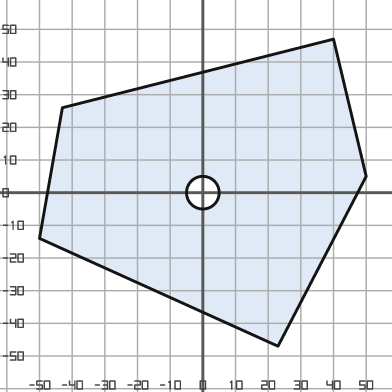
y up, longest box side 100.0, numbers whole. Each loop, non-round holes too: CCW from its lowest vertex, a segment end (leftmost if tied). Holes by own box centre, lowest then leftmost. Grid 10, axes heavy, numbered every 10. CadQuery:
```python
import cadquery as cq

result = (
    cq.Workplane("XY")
    .moveTo(23.0, -47.0)
    .lineTo(50.0, 5.0)
    .lineTo(40.0, 47.0)
    .lineTo(-43.0, 26.0)
    .lineTo(-50.0, -14.0)
    .close()
    .moveTo(0.0, 0.0)
    .circle(5.0)
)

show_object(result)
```